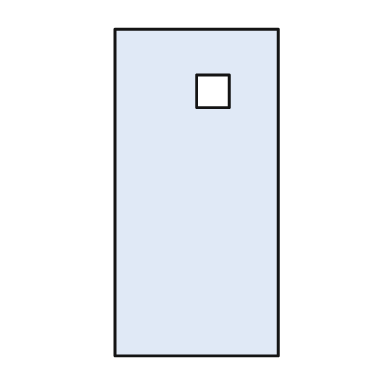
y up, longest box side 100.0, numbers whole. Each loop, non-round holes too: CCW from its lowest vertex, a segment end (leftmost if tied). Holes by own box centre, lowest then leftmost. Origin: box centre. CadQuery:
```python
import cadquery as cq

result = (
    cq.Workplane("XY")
    .moveTo(-25.0, -50.0)
    .lineTo(25.0, -50.0)
    .lineTo(25.0, 50.0)
    .lineTo(-25.0, 50.0)
    .close()
    .moveTo(0.0, 26.0)
    .lineTo(10.0, 26.0)
    .lineTo(10.0, 36.0)
    .lineTo(0.0, 36.0)
    .close()
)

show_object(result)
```